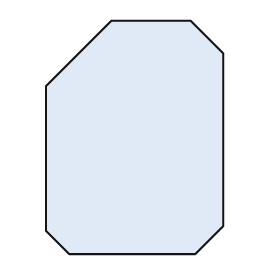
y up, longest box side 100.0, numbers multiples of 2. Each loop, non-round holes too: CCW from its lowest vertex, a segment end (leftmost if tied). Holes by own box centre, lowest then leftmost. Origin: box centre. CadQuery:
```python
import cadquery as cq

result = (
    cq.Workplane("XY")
    .moveTo(-28.0, -50.0)
    .lineTo(26.0, -50.0)
    .lineTo(38.0, -38.0)
    .lineTo(38.0, 36.0)
    .lineTo(24.0, 50.0)
    .lineTo(-10.0, 50.0)
    .lineTo(-38.0, 22.0)
    .lineTo(-38.0, -40.0)
    .close()
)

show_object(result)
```